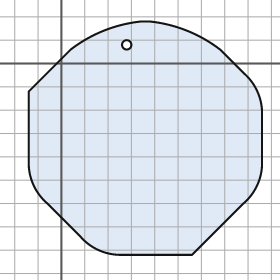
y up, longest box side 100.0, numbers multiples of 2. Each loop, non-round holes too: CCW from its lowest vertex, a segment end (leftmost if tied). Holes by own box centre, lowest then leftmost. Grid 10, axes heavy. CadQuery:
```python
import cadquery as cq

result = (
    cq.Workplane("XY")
    .moveTo(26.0, -82.0)
    .lineTo(56.0, -82.0)
    .lineTo(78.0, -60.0)
    .threePointArc((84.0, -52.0), (86.0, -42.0))
    .lineTo(86.0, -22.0)
    .threePointArc((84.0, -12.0), (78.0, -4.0))
    .lineTo(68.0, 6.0)
    .threePointArc((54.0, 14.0), (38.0, 18.0))
    .lineTo(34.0, 18.0)
    .threePointArc((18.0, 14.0), (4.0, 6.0))
    .lineTo(-14.0, -12.0)
    .lineTo(-14.0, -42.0)
    .threePointArc((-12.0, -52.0), (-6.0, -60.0))
    .lineTo(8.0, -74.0)
    .threePointArc((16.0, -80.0), (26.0, -82.0))
    .close()
    .moveTo(28.0, 8.0)
    .circle(2.0)
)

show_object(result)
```